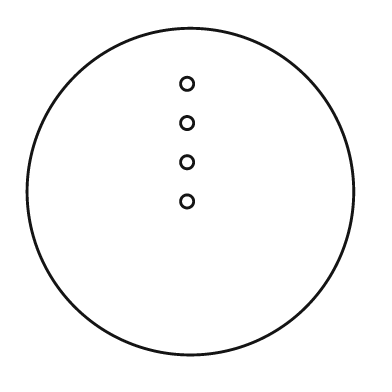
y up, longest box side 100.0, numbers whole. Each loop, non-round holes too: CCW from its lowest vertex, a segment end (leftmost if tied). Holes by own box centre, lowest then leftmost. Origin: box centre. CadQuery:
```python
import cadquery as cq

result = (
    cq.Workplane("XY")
    .moveTo(0.0, 0.0)
    .circle(50.0)
    .moveTo(-1.0, -3.0)
    .circle(2.0)
    .moveTo(-1.0, 9.0)
    .circle(2.0)
    .moveTo(-1.0, 21.0)
    .circle(2.0)
    .moveTo(-1.0, 33.0)
    .circle(2.0)
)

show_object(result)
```